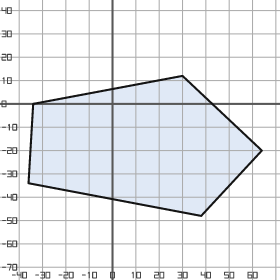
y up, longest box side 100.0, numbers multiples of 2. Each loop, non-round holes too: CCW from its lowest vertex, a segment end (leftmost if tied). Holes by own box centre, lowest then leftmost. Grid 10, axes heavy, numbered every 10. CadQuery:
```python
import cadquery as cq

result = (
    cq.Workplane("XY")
    .moveTo(38.0, -48.0)
    .lineTo(64.0, -20.0)
    .lineTo(30.0, 12.0)
    .lineTo(-34.0, 0.0)
    .lineTo(-36.0, -34.0)
    .close()
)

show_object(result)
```